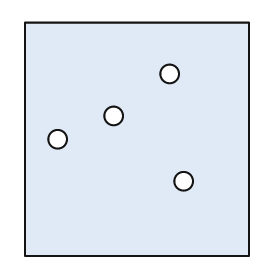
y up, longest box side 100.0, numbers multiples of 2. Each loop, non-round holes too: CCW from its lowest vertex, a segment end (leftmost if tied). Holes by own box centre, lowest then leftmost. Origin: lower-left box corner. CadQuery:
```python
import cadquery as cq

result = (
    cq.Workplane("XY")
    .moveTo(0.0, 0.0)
    .lineTo(96.0, 0.0)
    .lineTo(96.0, 100.0)
    .lineTo(0.0, 100.0)
    .close()
    .moveTo(68.0, 32.0)
    .circle(4.0)
    .moveTo(14.0, 50.0)
    .circle(4.0)
    .moveTo(38.0, 60.0)
    .circle(4.0)
    .moveTo(62.0, 78.0)
    .circle(4.0)
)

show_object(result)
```